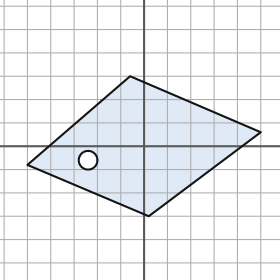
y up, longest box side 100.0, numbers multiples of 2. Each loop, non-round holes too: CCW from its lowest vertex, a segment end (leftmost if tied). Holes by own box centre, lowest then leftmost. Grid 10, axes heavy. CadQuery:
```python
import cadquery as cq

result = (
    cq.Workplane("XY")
    .moveTo(2.0, -30.0)
    .lineTo(50.0, 6.0)
    .lineTo(-6.0, 30.0)
    .lineTo(-50.0, -8.0)
    .close()
    .moveTo(-24.0, -6.0)
    .circle(4.0)
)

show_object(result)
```